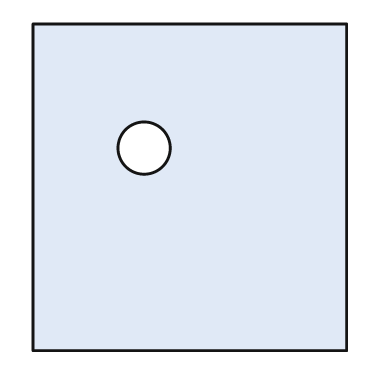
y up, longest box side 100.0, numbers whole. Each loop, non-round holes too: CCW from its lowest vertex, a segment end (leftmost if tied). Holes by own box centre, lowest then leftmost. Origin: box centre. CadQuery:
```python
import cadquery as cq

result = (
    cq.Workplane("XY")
    .moveTo(-48.0, -50.0)
    .lineTo(48.0, -50.0)
    .lineTo(48.0, 50.0)
    .lineTo(-48.0, 50.0)
    .close()
    .moveTo(-14.0, 12.0)
    .circle(8.0)
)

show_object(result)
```